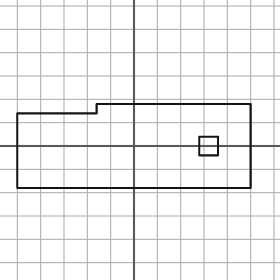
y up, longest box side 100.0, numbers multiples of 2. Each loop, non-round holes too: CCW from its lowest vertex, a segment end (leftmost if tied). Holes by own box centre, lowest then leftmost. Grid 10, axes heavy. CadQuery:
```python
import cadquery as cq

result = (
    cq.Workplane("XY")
    .moveTo(-50.0, -18.0)
    .lineTo(50.0, -18.0)
    .lineTo(50.0, 18.0)
    .lineTo(-16.0, 18.0)
    .lineTo(-16.0, 14.0)
    .lineTo(-50.0, 14.0)
    .close()
    .moveTo(28.0, -4.0)
    .lineTo(36.0, -4.0)
    .lineTo(36.0, 4.0)
    .lineTo(28.0, 4.0)
    .close()
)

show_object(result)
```